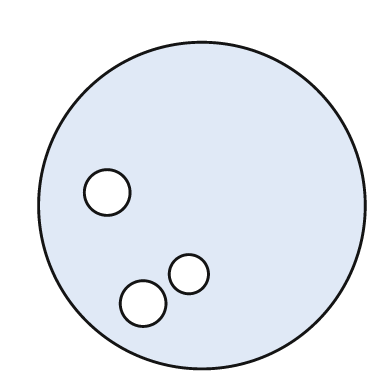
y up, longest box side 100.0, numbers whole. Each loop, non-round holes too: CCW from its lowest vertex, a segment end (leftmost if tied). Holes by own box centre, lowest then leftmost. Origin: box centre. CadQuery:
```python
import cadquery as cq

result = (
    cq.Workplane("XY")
    .moveTo(0.0, 0.0)
    .circle(50.0)
    .moveTo(-18.0, -30.0)
    .circle(7.0)
    .moveTo(-4.0, -21.0)
    .circle(6.0)
    .moveTo(-29.0, 4.0)
    .circle(7.0)
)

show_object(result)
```